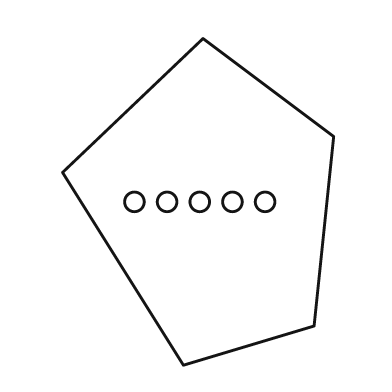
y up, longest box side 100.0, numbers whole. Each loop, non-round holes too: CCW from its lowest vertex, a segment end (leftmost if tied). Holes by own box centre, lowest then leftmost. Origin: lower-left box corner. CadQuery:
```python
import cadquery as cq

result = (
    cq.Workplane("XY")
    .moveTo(37.0, 0.0)
    .lineTo(77.0, 12.0)
    .lineTo(83.0, 70.0)
    .lineTo(43.0, 100.0)
    .lineTo(0.0, 59.0)
    .close()
    .moveTo(22.0, 50.0)
    .circle(3.0)
    .moveTo(32.0, 50.0)
    .circle(3.0)
    .moveTo(42.0, 50.0)
    .circle(3.0)
    .moveTo(52.0, 50.0)
    .circle(3.0)
    .moveTo(62.0, 50.0)
    .circle(3.0)
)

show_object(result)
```